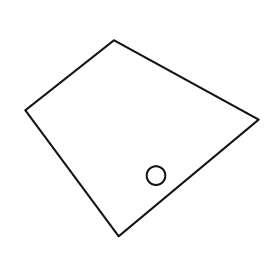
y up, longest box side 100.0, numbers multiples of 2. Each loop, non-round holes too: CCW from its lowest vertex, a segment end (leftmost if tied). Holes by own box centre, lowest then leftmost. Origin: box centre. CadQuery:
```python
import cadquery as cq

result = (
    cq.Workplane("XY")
    .moveTo(-10.0, -42.0)
    .lineTo(50.0, 8.0)
    .lineTo(-12.0, 42.0)
    .lineTo(-50.0, 12.0)
    .close()
    .moveTo(6.0, -16.0)
    .circle(4.0)
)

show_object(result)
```